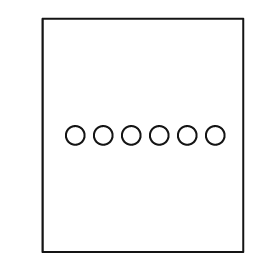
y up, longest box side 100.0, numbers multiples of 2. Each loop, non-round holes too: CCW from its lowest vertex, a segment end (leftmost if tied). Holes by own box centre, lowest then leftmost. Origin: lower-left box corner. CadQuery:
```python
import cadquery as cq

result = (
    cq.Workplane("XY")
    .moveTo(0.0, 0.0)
    .lineTo(86.0, 0.0)
    .lineTo(86.0, 100.0)
    .lineTo(0.0, 100.0)
    .close()
    .moveTo(14.0, 50.0)
    .circle(4.0)
    .moveTo(26.0, 50.0)
    .circle(4.0)
    .moveTo(38.0, 50.0)
    .circle(4.0)
    .moveTo(50.0, 50.0)
    .circle(4.0)
    .moveTo(62.0, 50.0)
    .circle(4.0)
    .moveTo(74.0, 50.0)
    .circle(4.0)
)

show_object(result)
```